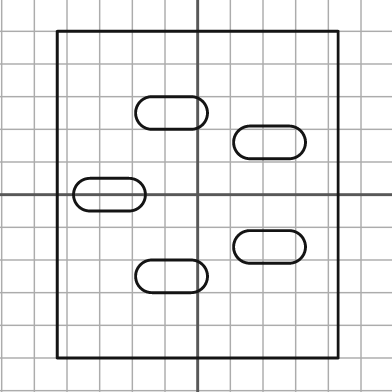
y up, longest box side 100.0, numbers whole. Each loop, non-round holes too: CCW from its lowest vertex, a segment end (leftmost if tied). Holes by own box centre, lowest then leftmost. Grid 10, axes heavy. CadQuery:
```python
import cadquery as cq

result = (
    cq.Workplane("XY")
    .moveTo(-43.0, -50.0)
    .lineTo(43.0, -50.0)
    .lineTo(43.0, 50.0)
    .lineTo(-43.0, 50.0)
    .close()
    .moveTo(-14.0, -30.0)
    .lineTo(-2.0, -30.0)
    .threePointArc((3.0, -25.0), (-2.0, -20.0))
    .lineTo(-14.0, -20.0)
    .threePointArc((-19.0, -25.0), (-14.0, -30.0))
    .close()
    .moveTo(16.0, -21.0)
    .lineTo(28.0, -21.0)
    .threePointArc((33.0, -16.0), (28.0, -11.0))
    .lineTo(16.0, -11.0)
    .threePointArc((11.0, -16.0), (16.0, -21.0))
    .close()
    .moveTo(-33.0, -5.0)
    .lineTo(-21.0, -5.0)
    .threePointArc((-16.0, 0.0), (-21.0, 5.0))
    .lineTo(-33.0, 5.0)
    .threePointArc((-38.0, 0.0), (-33.0, -5.0))
    .close()
    .moveTo(16.0, 11.0)
    .lineTo(28.0, 11.0)
    .threePointArc((33.0, 16.0), (28.0, 21.0))
    .lineTo(16.0, 21.0)
    .threePointArc((11.0, 16.0), (16.0, 11.0))
    .close()
    .moveTo(-14.0, 20.0)
    .lineTo(-2.0, 20.0)
    .threePointArc((3.0, 25.0), (-2.0, 30.0))
    .lineTo(-14.0, 30.0)
    .threePointArc((-19.0, 25.0), (-14.0, 20.0))
    .close()
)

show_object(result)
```